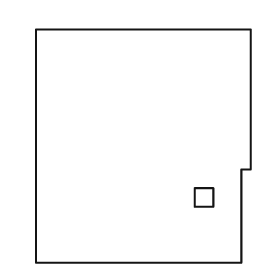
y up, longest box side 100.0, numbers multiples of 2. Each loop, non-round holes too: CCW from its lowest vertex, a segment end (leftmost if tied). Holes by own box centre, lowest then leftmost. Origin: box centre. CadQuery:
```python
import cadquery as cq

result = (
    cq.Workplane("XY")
    .moveTo(-46.0, -50.0)
    .lineTo(42.0, -50.0)
    .lineTo(42.0, -10.0)
    .lineTo(46.0, -10.0)
    .lineTo(46.0, 50.0)
    .lineTo(-46.0, 50.0)
    .close()
    .moveTo(22.0, -26.0)
    .lineTo(30.0, -26.0)
    .lineTo(30.0, -18.0)
    .lineTo(22.0, -18.0)
    .close()
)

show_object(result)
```